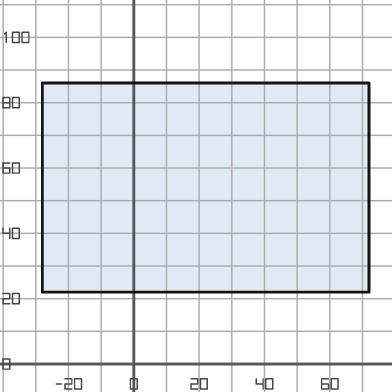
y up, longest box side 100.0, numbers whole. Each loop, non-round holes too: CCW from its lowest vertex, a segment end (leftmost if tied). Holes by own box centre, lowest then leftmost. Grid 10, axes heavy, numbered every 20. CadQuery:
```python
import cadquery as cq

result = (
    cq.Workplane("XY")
    .moveTo(-28.0, 22.0)
    .lineTo(72.0, 22.0)
    .lineTo(72.0, 86.0)
    .lineTo(-28.0, 86.0)
    .close()
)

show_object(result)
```